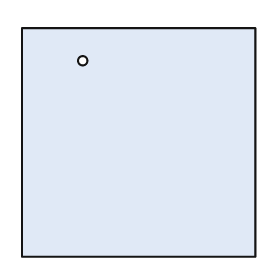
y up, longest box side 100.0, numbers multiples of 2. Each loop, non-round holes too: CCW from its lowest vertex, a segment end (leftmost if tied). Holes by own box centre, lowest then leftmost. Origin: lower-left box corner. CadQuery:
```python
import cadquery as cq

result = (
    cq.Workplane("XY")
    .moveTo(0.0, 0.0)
    .lineTo(100.0, 0.0)
    .lineTo(100.0, 98.0)
    .lineTo(0.0, 98.0)
    .close()
    .moveTo(26.0, 84.0)
    .circle(2.0)
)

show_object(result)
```